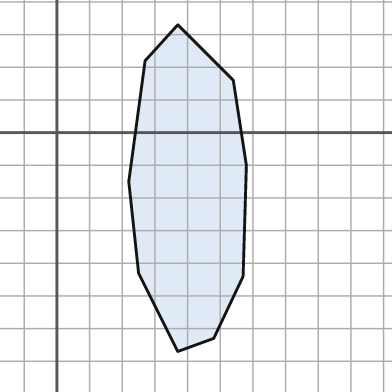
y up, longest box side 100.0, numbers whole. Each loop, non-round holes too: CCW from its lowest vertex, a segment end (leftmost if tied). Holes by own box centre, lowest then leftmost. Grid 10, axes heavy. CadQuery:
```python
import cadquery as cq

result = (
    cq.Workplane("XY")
    .moveTo(37.0, -67.0)
    .lineTo(48.0, -63.0)
    .lineTo(57.0, -44.0)
    .lineTo(58.0, -10.0)
    .lineTo(54.0, 16.0)
    .lineTo(37.0, 33.0)
    .lineTo(27.0, 22.0)
    .lineTo(22.0, -15.0)
    .lineTo(25.0, -43.0)
    .close()
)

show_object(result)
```